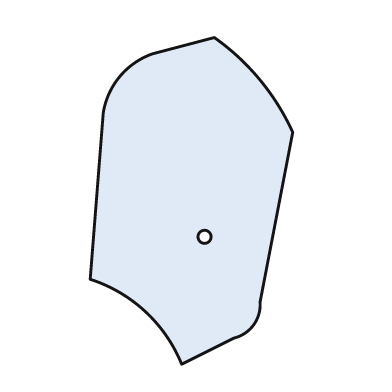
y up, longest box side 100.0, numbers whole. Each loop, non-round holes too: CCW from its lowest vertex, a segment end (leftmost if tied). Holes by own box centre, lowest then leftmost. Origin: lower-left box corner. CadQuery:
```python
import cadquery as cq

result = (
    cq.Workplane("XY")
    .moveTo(28.0, 0.0)
    .lineTo(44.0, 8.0)
    .threePointArc((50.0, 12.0), (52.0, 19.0))
    .lineTo(62.0, 71.0)
    .threePointArc((52.0, 87.0), (38.0, 100.0))
    .lineTo(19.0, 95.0)
    .threePointArc((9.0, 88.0), (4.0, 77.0))
    .lineTo(0.0, 26.0)
    .threePointArc((17.0, 16.0), (28.0, 0.0))
    .close()
    .moveTo(35.0, 39.0)
    .circle(2.0)
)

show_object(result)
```